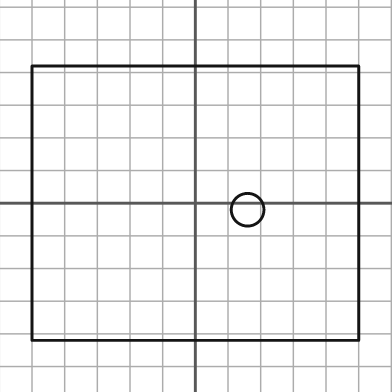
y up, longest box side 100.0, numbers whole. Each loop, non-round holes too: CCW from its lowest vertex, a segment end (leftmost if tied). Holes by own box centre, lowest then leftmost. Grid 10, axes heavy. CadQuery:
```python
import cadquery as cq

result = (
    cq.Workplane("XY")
    .moveTo(-50.0, -42.0)
    .lineTo(50.0, -42.0)
    .lineTo(50.0, 42.0)
    .lineTo(-50.0, 42.0)
    .close()
    .moveTo(16.0, -2.0)
    .circle(5.0)
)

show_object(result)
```